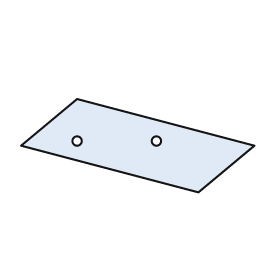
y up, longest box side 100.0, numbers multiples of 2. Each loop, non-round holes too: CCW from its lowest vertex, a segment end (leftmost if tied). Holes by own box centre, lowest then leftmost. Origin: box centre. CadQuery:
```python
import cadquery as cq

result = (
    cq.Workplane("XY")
    .moveTo(26.0, -20.0)
    .lineTo(50.0, 0.0)
    .lineTo(-26.0, 20.0)
    .lineTo(-50.0, 0.0)
    .close()
    .moveTo(-26.0, 2.0)
    .circle(2.0)
    .moveTo(8.0, 2.0)
    .circle(2.0)
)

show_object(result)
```